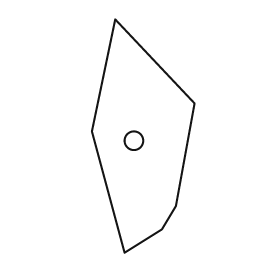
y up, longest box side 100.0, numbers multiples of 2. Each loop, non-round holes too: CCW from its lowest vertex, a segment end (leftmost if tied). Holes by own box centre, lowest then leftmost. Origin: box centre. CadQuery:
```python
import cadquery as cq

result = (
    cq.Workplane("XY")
    .moveTo(-8.0, -50.0)
    .lineTo(8.0, -40.0)
    .lineTo(14.0, -30.0)
    .lineTo(22.0, 14.0)
    .lineTo(-12.0, 50.0)
    .lineTo(-22.0, 2.0)
    .close()
    .moveTo(-4.0, -2.0)
    .circle(4.0)
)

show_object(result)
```